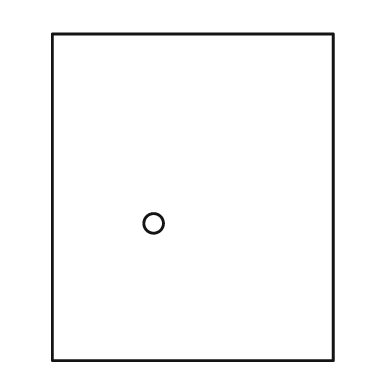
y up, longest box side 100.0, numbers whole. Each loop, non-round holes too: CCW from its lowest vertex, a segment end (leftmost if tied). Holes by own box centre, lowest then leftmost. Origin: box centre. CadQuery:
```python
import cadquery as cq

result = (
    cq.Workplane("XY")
    .moveTo(-43.0, -50.0)
    .lineTo(43.0, -50.0)
    .lineTo(43.0, 50.0)
    .lineTo(-43.0, 50.0)
    .close()
    .moveTo(-12.0, -8.0)
    .circle(3.0)
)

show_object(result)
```